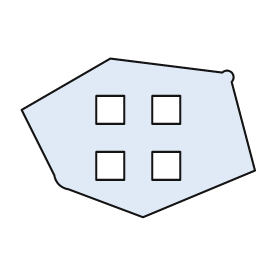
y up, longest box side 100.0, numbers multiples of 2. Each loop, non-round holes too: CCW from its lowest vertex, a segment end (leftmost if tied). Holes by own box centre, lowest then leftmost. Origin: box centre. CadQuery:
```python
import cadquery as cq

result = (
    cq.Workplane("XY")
    .moveTo(2.0, -34.0)
    .lineTo(50.0, -14.0)
    .lineTo(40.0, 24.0)
    .threePointArc((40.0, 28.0), (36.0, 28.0))
    .lineTo(-12.0, 34.0)
    .lineTo(-50.0, 12.0)
    .lineTo(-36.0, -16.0)
    .threePointArc((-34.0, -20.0), (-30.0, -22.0))
    .close()
    .moveTo(-18.0, -18.0)
    .lineTo(-6.0, -18.0)
    .lineTo(-6.0, -6.0)
    .lineTo(-18.0, -6.0)
    .close()
    .moveTo(6.0, -18.0)
    .lineTo(18.0, -18.0)
    .lineTo(18.0, -6.0)
    .lineTo(6.0, -6.0)
    .close()
    .moveTo(-18.0, 6.0)
    .lineTo(-6.0, 6.0)
    .lineTo(-6.0, 18.0)
    .lineTo(-18.0, 18.0)
    .close()
    .moveTo(6.0, 6.0)
    .lineTo(18.0, 6.0)
    .lineTo(18.0, 18.0)
    .lineTo(6.0, 18.0)
    .close()
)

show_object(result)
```